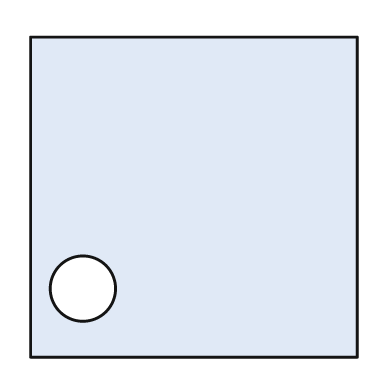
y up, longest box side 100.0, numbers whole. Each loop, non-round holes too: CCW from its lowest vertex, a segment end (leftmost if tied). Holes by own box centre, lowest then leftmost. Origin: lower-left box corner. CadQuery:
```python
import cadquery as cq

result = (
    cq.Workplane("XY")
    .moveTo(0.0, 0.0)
    .lineTo(100.0, 0.0)
    .lineTo(100.0, 98.0)
    .lineTo(0.0, 98.0)
    .close()
    .moveTo(16.0, 21.0)
    .circle(10.0)
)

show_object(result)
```